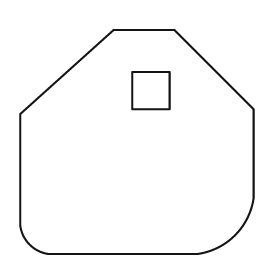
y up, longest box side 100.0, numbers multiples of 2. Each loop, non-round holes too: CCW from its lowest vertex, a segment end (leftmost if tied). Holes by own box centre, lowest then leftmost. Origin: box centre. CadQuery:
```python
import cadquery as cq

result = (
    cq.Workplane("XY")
    .moveTo(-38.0, -48.0)
    .lineTo(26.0, -48.0)
    .threePointArc((42.0, -40.0), (50.0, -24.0))
    .lineTo(50.0, 14.0)
    .lineTo(16.0, 48.0)
    .lineTo(-10.0, 48.0)
    .lineTo(-50.0, 12.0)
    .lineTo(-50.0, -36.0)
    .threePointArc((-46.0, -44.0), (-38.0, -48.0))
    .close()
    .moveTo(-2.0, 14.0)
    .lineTo(14.0, 14.0)
    .lineTo(14.0, 30.0)
    .lineTo(-2.0, 30.0)
    .close()
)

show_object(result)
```